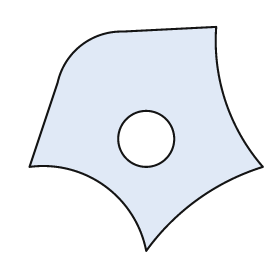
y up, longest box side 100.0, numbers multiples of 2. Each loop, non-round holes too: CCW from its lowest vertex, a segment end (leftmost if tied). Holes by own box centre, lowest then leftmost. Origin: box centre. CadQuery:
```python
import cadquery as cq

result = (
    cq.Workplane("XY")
    .moveTo(0.0, -48.0)
    .threePointArc((22.0, -26.0), (50.0, -12.0))
    .threePointArc((34.0, 16.0), (30.0, 48.0))
    .lineTo(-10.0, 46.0)
    .threePointArc((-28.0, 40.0), (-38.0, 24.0))
    .lineTo(-50.0, -12.0)
    .threePointArc((-18.0, -20.0), (0.0, -48.0))
    .close()
    .moveTo(0.0, 0.0)
    .circle(12.0)
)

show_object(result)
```